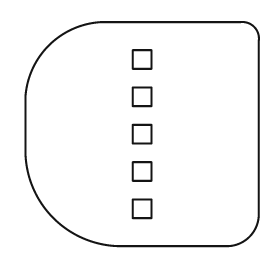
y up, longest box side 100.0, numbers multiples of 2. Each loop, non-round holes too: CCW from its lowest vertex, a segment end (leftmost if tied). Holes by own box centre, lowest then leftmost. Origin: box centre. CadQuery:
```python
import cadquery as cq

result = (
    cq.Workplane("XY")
    .moveTo(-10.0, -48.0)
    .lineTo(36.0, -48.0)
    .threePointArc((46.0, -44.0), (50.0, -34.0))
    .lineTo(50.0, 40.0)
    .threePointArc((48.0, 46.0), (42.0, 48.0))
    .lineTo(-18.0, 48.0)
    .threePointArc((-40.0, 38.0), (-50.0, 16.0))
    .lineTo(-50.0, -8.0)
    .threePointArc((-38.0, -36.0), (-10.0, -48.0))
    .close()
    .moveTo(-4.0, -36.0)
    .lineTo(4.0, -36.0)
    .lineTo(4.0, -28.0)
    .lineTo(-4.0, -28.0)
    .close()
    .moveTo(-4.0, -20.0)
    .lineTo(4.0, -20.0)
    .lineTo(4.0, -12.0)
    .lineTo(-4.0, -12.0)
    .close()
    .moveTo(-4.0, -4.0)
    .lineTo(4.0, -4.0)
    .lineTo(4.0, 4.0)
    .lineTo(-4.0, 4.0)
    .close()
    .moveTo(-4.0, 12.0)
    .lineTo(4.0, 12.0)
    .lineTo(4.0, 20.0)
    .lineTo(-4.0, 20.0)
    .close()
    .moveTo(-4.0, 28.0)
    .lineTo(4.0, 28.0)
    .lineTo(4.0, 36.0)
    .lineTo(-4.0, 36.0)
    .close()
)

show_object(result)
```